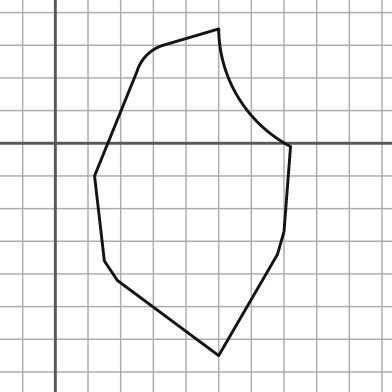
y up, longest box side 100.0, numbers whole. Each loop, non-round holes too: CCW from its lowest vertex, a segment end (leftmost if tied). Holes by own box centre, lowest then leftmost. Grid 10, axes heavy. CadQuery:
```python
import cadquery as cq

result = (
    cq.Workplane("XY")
    .moveTo(50.0, -65.0)
    .lineTo(68.0, -34.0)
    .lineTo(70.0, -27.0)
    .lineTo(72.0, -1.0)
    .threePointArc((56.0, 14.0), (50.0, 35.0))
    .lineTo(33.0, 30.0)
    .threePointArc((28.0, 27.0), (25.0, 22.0))
    .lineTo(12.0, -10.0)
    .lineTo(15.0, -36.0)
    .lineTo(19.0, -42.0)
    .close()
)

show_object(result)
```